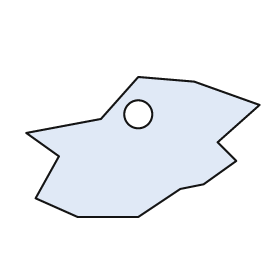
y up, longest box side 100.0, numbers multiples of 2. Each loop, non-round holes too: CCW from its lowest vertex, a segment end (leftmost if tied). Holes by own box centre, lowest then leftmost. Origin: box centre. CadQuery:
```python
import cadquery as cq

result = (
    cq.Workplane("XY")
    .moveTo(-28.0, -30.0)
    .lineTo(-2.0, -30.0)
    .lineTo(16.0, -18.0)
    .lineTo(26.0, -16.0)
    .lineTo(40.0, -6.0)
    .lineTo(32.0, 2.0)
    .lineTo(50.0, 18.0)
    .lineTo(22.0, 28.0)
    .lineTo(-2.0, 30.0)
    .lineTo(-18.0, 12.0)
    .lineTo(-50.0, 6.0)
    .lineTo(-36.0, -4.0)
    .lineTo(-46.0, -22.0)
    .close()
    .moveTo(-2.0, 14.0)
    .circle(6.0)
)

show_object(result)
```